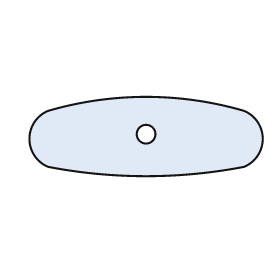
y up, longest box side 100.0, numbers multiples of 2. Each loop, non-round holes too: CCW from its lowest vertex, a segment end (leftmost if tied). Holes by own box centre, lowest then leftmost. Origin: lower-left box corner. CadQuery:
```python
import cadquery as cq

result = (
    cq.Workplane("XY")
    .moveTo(8.0, 4.0)
    .threePointArc((50.0, 0.0), (92.0, 4.0))
    .threePointArc((100.0, 16.0), (92.0, 28.0))
    .threePointArc((50.0, 34.0), (8.0, 28.0))
    .threePointArc((0.0, 16.0), (8.0, 4.0))
    .close()
    .moveTo(50.0, 18.0)
    .circle(4.0)
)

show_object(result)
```